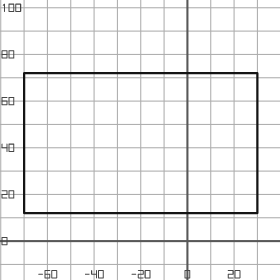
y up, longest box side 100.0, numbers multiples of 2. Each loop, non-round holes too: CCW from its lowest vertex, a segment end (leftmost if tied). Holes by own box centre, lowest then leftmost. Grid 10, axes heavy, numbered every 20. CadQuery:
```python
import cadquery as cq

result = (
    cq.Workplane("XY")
    .moveTo(-70.0, 12.0)
    .lineTo(30.0, 12.0)
    .lineTo(30.0, 72.0)
    .lineTo(-70.0, 72.0)
    .close()
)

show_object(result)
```